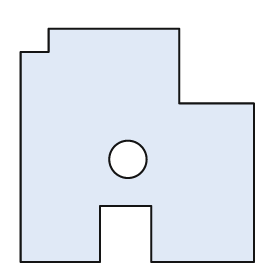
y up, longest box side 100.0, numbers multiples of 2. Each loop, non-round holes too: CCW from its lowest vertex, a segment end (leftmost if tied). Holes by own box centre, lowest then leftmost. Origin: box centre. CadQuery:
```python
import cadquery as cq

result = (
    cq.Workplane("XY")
    .moveTo(-50.0, -50.0)
    .lineTo(-16.0, -50.0)
    .lineTo(-16.0, -26.0)
    .lineTo(6.0, -26.0)
    .lineTo(6.0, -50.0)
    .lineTo(50.0, -50.0)
    .lineTo(50.0, 18.0)
    .lineTo(18.0, 18.0)
    .lineTo(18.0, 50.0)
    .lineTo(-38.0, 50.0)
    .lineTo(-38.0, 40.0)
    .lineTo(-50.0, 40.0)
    .close()
    .moveTo(-4.0, -6.0)
    .circle(8.0)
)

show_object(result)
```